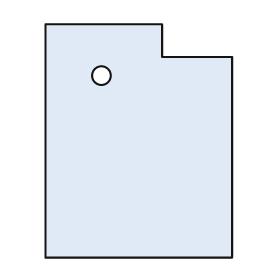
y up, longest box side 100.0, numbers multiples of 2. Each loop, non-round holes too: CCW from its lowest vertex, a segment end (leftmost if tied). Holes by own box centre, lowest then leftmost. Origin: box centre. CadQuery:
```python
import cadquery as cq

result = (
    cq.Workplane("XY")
    .moveTo(-40.0, -50.0)
    .lineTo(40.0, -50.0)
    .lineTo(40.0, 36.0)
    .lineTo(10.0, 36.0)
    .lineTo(10.0, 50.0)
    .lineTo(-40.0, 50.0)
    .close()
    .moveTo(-16.0, 28.0)
    .circle(4.0)
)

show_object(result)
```